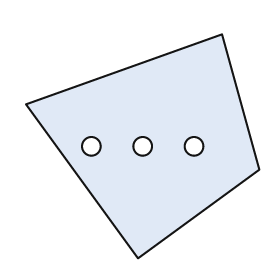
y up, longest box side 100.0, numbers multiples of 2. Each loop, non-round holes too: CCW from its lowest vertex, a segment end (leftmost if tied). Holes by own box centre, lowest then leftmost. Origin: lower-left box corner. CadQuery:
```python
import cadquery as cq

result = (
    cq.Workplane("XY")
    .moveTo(48.0, 0.0)
    .lineTo(100.0, 38.0)
    .lineTo(84.0, 96.0)
    .lineTo(0.0, 66.0)
    .close()
    .moveTo(28.0, 48.0)
    .circle(4.0)
    .moveTo(50.0, 48.0)
    .circle(4.0)
    .moveTo(72.0, 48.0)
    .circle(4.0)
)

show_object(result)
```